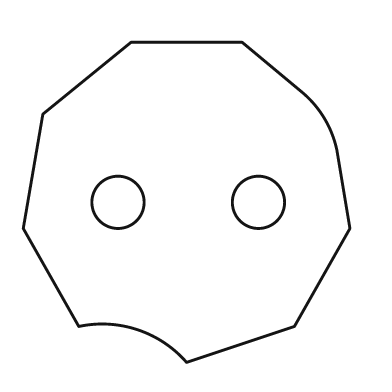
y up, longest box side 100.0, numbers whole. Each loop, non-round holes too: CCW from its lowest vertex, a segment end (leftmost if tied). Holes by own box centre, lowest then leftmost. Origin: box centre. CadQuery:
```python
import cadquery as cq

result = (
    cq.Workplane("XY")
    .moveTo(0.0, -49.0)
    .lineTo(33.0, -38.0)
    .lineTo(50.0, -8.0)
    .lineTo(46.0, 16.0)
    .threePointArc((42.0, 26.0), (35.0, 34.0))
    .lineTo(17.0, 49.0)
    .lineTo(-17.0, 49.0)
    .lineTo(-44.0, 27.0)
    .lineTo(-50.0, -8.0)
    .lineTo(-33.0, -38.0)
    .threePointArc((-15.0, -39.0), (0.0, -49.0))
    .close()
    .moveTo(-21.0, 0.0)
    .circle(8.0)
    .moveTo(22.0, 0.0)
    .circle(8.0)
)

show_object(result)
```